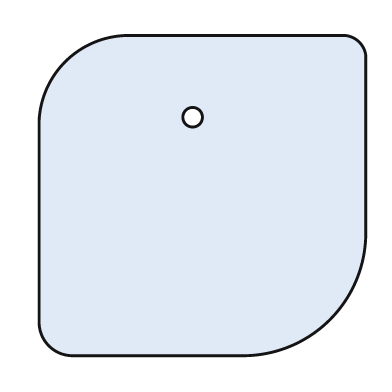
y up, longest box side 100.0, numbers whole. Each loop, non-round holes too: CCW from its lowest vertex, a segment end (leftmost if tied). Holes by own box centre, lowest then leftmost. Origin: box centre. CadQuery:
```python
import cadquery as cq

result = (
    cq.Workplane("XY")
    .moveTo(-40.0, -49.0)
    .lineTo(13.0, -49.0)
    .threePointArc((39.0, -38.0), (50.0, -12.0))
    .lineTo(50.0, 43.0)
    .threePointArc((48.0, 47.0), (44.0, 49.0))
    .lineTo(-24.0, 49.0)
    .threePointArc((-42.0, 41.0), (-50.0, 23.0))
    .lineTo(-50.0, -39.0)
    .threePointArc((-47.0, -46.0), (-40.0, -49.0))
    .close()
    .moveTo(-3.0, 24.0)
    .circle(3.0)
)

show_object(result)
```